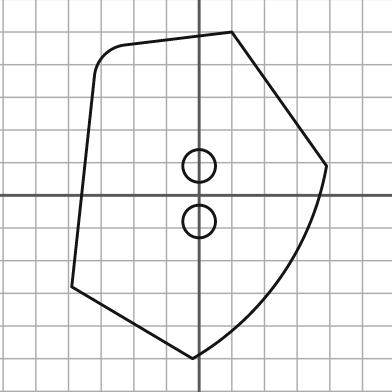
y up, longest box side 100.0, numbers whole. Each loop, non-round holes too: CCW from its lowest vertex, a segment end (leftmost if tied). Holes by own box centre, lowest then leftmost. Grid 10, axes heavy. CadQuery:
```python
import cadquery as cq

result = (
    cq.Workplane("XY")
    .moveTo(-2.0, -50.0)
    .threePointArc((25.0, -25.0), (39.0, 9.0))
    .lineTo(10.0, 50.0)
    .lineTo(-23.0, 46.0)
    .threePointArc((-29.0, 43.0), (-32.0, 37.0))
    .lineTo(-39.0, -28.0)
    .close()
    .moveTo(0.0, -8.0)
    .circle(5.0)
    .moveTo(0.0, 9.0)
    .circle(5.0)
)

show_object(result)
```